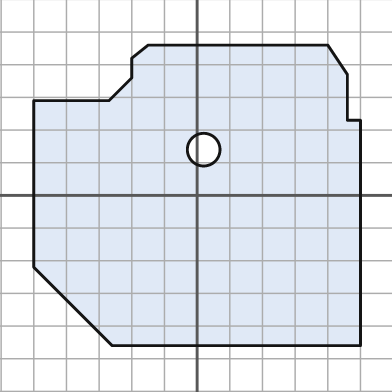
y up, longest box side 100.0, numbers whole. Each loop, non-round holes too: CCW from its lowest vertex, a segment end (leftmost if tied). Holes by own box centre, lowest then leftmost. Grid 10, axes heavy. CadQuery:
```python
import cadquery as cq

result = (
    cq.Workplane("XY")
    .moveTo(-26.0, -46.0)
    .lineTo(50.0, -46.0)
    .lineTo(50.0, 23.0)
    .lineTo(46.0, 23.0)
    .lineTo(46.0, 37.0)
    .lineTo(40.0, 46.0)
    .lineTo(-15.0, 46.0)
    .lineTo(-20.0, 42.0)
    .lineTo(-20.0, 36.0)
    .lineTo(-27.0, 29.0)
    .lineTo(-50.0, 29.0)
    .lineTo(-50.0, -22.0)
    .close()
    .moveTo(2.0, 14.0)
    .circle(5.0)
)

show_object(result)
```